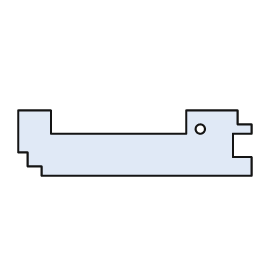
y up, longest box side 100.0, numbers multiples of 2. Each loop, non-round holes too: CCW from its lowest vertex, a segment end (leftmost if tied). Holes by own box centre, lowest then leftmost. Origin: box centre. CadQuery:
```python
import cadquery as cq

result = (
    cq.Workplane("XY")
    .moveTo(-40.0, -14.0)
    .lineTo(50.0, -14.0)
    .lineTo(50.0, -6.0)
    .lineTo(42.0, -6.0)
    .lineTo(42.0, 4.0)
    .lineTo(50.0, 4.0)
    .lineTo(50.0, 8.0)
    .lineTo(44.0, 8.0)
    .lineTo(44.0, 14.0)
    .lineTo(22.0, 14.0)
    .lineTo(22.0, 4.0)
    .lineTo(-36.0, 4.0)
    .lineTo(-36.0, 14.0)
    .lineTo(-50.0, 14.0)
    .lineTo(-50.0, -4.0)
    .lineTo(-46.0, -4.0)
    .lineTo(-46.0, -10.0)
    .lineTo(-40.0, -10.0)
    .close()
    .moveTo(28.0, 6.0)
    .circle(2.0)
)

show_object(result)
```